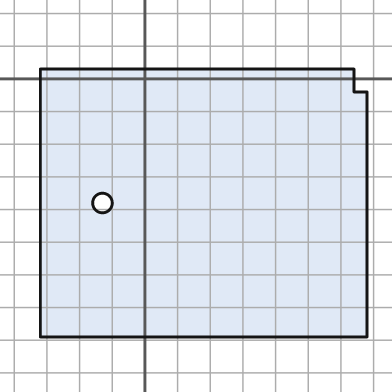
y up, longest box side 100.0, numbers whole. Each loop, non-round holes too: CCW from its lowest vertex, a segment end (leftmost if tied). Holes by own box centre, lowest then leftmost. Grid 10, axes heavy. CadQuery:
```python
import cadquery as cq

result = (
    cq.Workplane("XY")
    .moveTo(-32.0, -79.0)
    .lineTo(68.0, -79.0)
    .lineTo(68.0, -4.0)
    .lineTo(64.0, -4.0)
    .lineTo(64.0, 3.0)
    .lineTo(-32.0, 3.0)
    .close()
    .moveTo(-13.0, -38.0)
    .circle(3.0)
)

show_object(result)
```